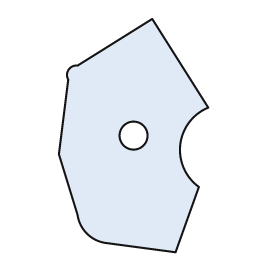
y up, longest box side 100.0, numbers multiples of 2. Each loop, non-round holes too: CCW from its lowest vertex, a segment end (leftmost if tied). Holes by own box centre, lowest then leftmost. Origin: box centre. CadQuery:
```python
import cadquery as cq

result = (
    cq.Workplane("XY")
    .moveTo(18.0, -50.0)
    .lineTo(28.0, -22.0)
    .threePointArc((20.0, -4.0), (32.0, 12.0))
    .lineTo(8.0, 50.0)
    .lineTo(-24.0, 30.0)
    .threePointArc((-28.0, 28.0), (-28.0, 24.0))
    .lineTo(-32.0, -8.0)
    .lineTo(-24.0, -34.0)
    .threePointArc((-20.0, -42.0), (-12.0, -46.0))
    .close()
    .moveTo(0.0, 0.0)
    .circle(6.0)
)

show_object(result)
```